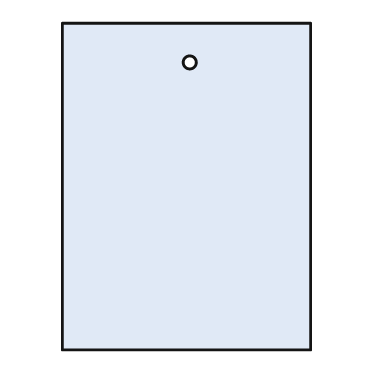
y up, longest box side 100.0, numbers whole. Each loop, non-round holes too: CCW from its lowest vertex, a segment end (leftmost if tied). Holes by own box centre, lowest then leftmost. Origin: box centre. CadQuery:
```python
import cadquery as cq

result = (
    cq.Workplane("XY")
    .moveTo(-38.0, -50.0)
    .lineTo(38.0, -50.0)
    .lineTo(38.0, 50.0)
    .lineTo(-38.0, 50.0)
    .close()
    .moveTo(1.0, 38.0)
    .circle(2.0)
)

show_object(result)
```